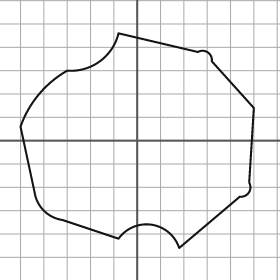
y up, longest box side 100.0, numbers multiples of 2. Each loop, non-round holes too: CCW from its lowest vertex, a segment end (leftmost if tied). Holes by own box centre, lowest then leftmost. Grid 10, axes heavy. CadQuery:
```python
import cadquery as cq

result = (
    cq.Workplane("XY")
    .moveTo(18.0, -46.0)
    .lineTo(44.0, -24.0)
    .threePointArc((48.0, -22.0), (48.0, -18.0))
    .lineTo(50.0, 14.0)
    .lineTo(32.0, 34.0)
    .threePointArc((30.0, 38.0), (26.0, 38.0))
    .lineTo(-8.0, 46.0)
    .threePointArc((-16.0, 34.0), (-30.0, 30.0))
    .threePointArc((-42.0, 20.0), (-50.0, 6.0))
    .lineTo(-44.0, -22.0)
    .threePointArc((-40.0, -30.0), (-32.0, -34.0))
    .lineTo(-8.0, -42.0)
    .threePointArc((6.0, -36.0), (18.0, -46.0))
    .close()
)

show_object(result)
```